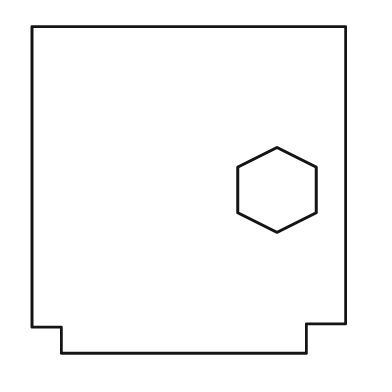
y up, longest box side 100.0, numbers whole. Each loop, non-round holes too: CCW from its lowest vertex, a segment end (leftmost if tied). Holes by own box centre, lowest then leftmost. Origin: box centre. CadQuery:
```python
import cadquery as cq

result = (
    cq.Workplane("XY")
    .moveTo(-39.0, -50.0)
    .lineTo(36.0, -50.0)
    .lineTo(36.0, -41.0)
    .lineTo(48.0, -41.0)
    .lineTo(48.0, 50.0)
    .lineTo(-48.0, 50.0)
    .lineTo(-48.0, -42.0)
    .lineTo(-39.0, -42.0)
    .close()
    .moveTo(27.0, -13.0)
    .lineTo(39.0, -7.0)
    .lineTo(39.0, 7.0)
    .lineTo(27.0, 13.0)
    .lineTo(15.0, 7.0)
    .lineTo(15.0, -7.0)
    .close()
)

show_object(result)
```